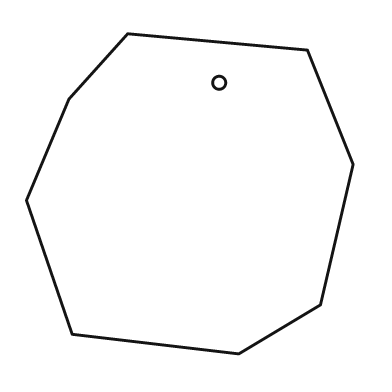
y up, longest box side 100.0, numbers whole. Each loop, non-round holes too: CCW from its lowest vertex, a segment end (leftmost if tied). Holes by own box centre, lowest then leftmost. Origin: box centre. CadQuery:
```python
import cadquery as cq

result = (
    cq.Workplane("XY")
    .moveTo(15.0, -49.0)
    .lineTo(40.0, -34.0)
    .lineTo(50.0, 9.0)
    .lineTo(36.0, 44.0)
    .lineTo(-19.0, 49.0)
    .lineTo(-37.0, 29.0)
    .lineTo(-50.0, -2.0)
    .lineTo(-36.0, -43.0)
    .close()
    .moveTo(9.0, 34.0)
    .circle(2.0)
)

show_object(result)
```